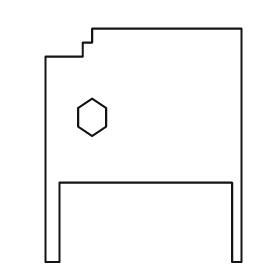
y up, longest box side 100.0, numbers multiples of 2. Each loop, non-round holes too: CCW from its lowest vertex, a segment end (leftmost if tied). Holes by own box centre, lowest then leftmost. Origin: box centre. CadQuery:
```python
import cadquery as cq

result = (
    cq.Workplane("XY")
    .moveTo(-42.0, -50.0)
    .lineTo(-36.0, -50.0)
    .lineTo(-36.0, -16.0)
    .lineTo(38.0, -16.0)
    .lineTo(38.0, -50.0)
    .lineTo(42.0, -50.0)
    .lineTo(42.0, 50.0)
    .lineTo(-22.0, 50.0)
    .lineTo(-22.0, 44.0)
    .lineTo(-26.0, 44.0)
    .lineTo(-26.0, 38.0)
    .lineTo(-42.0, 38.0)
    .close()
    .moveTo(-22.0, 4.0)
    .lineTo(-16.0, 8.0)
    .lineTo(-16.0, 16.0)
    .lineTo(-22.0, 20.0)
    .lineTo(-28.0, 16.0)
    .lineTo(-28.0, 8.0)
    .close()
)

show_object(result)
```